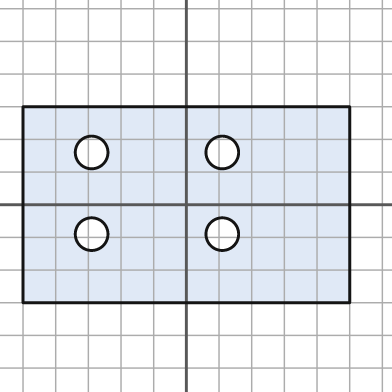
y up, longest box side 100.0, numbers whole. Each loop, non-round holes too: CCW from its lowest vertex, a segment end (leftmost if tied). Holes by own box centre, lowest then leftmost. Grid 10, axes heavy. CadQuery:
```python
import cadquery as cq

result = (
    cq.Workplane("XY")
    .moveTo(-50.0, -30.0)
    .lineTo(50.0, -30.0)
    .lineTo(50.0, 30.0)
    .lineTo(-50.0, 30.0)
    .close()
    .moveTo(-29.0, -9.0)
    .circle(5.0)
    .moveTo(11.0, -9.0)
    .circle(5.0)
    .moveTo(-29.0, 16.0)
    .circle(5.0)
    .moveTo(11.0, 16.0)
    .circle(5.0)
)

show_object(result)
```